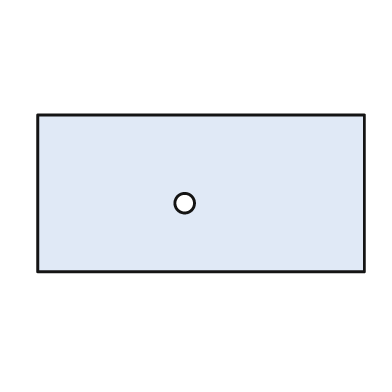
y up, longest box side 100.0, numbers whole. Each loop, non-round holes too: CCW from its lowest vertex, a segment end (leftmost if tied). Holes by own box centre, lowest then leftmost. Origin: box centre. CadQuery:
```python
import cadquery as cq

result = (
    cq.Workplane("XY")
    .moveTo(-50.0, -24.0)
    .lineTo(50.0, -24.0)
    .lineTo(50.0, 24.0)
    .lineTo(-50.0, 24.0)
    .close()
    .moveTo(-5.0, -3.0)
    .circle(3.0)
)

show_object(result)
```